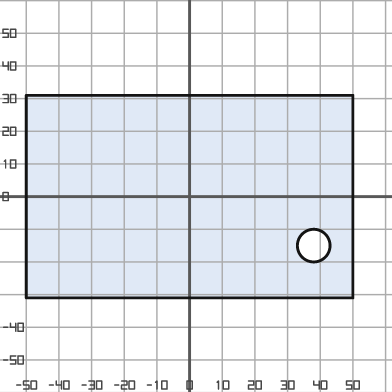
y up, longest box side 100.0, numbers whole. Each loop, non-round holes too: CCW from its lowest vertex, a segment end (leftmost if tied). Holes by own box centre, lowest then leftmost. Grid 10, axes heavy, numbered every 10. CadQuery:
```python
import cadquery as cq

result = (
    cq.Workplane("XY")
    .moveTo(-50.0, -31.0)
    .lineTo(50.0, -31.0)
    .lineTo(50.0, 31.0)
    .lineTo(-50.0, 31.0)
    .close()
    .moveTo(38.0, -15.0)
    .circle(5.0)
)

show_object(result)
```